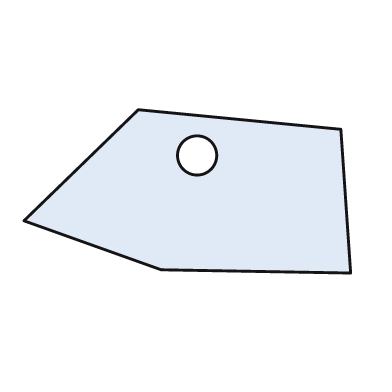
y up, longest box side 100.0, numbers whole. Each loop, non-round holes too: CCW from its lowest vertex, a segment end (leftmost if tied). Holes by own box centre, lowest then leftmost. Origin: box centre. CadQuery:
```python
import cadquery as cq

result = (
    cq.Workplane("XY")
    .moveTo(50.0, -25.0)
    .lineTo(47.0, 19.0)
    .lineTo(-15.0, 25.0)
    .lineTo(-50.0, -9.0)
    .lineTo(-8.0, -24.0)
    .close()
    .moveTo(3.0, 11.0)
    .circle(6.0)
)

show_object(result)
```